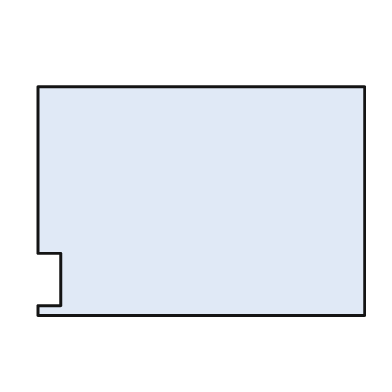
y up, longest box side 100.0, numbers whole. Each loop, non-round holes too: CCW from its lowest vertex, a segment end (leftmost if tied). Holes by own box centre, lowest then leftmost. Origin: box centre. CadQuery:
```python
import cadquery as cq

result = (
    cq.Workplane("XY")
    .moveTo(-50.0, -35.0)
    .lineTo(50.0, -35.0)
    .lineTo(50.0, 35.0)
    .lineTo(-50.0, 35.0)
    .lineTo(-50.0, -16.0)
    .lineTo(-43.0, -16.0)
    .lineTo(-43.0, -32.0)
    .lineTo(-50.0, -32.0)
    .close()
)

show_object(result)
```